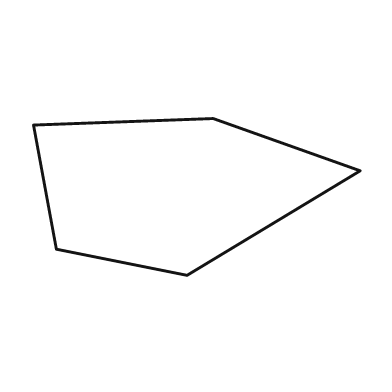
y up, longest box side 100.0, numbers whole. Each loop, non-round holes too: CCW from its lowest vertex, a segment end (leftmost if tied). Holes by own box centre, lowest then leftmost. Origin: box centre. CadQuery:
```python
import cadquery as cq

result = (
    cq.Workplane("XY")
    .moveTo(-3.0, -24.0)
    .lineTo(50.0, 8.0)
    .lineTo(5.0, 24.0)
    .lineTo(-50.0, 22.0)
    .lineTo(-43.0, -16.0)
    .close()
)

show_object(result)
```